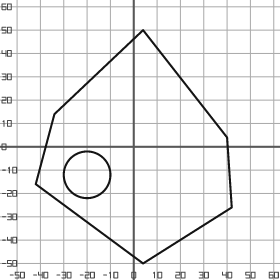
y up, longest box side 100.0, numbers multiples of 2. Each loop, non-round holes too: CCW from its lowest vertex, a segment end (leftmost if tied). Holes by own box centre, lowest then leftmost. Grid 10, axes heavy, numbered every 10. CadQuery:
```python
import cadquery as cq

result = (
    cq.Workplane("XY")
    .moveTo(4.0, -50.0)
    .lineTo(42.0, -26.0)
    .lineTo(40.0, 4.0)
    .lineTo(4.0, 50.0)
    .lineTo(-34.0, 14.0)
    .lineTo(-42.0, -16.0)
    .close()
    .moveTo(-20.0, -12.0)
    .circle(10.0)
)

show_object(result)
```